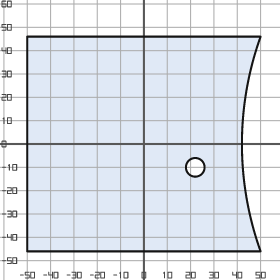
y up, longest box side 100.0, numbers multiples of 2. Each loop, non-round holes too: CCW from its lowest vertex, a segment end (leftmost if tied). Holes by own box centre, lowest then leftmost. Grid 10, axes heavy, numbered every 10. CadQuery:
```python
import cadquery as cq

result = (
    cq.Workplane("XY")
    .moveTo(-50.0, -46.0)
    .lineTo(50.0, -46.0)
    .threePointArc((42.0, 0.0), (50.0, 46.0))
    .lineTo(-50.0, 46.0)
    .close()
    .moveTo(22.0, -10.0)
    .circle(4.0)
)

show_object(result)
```